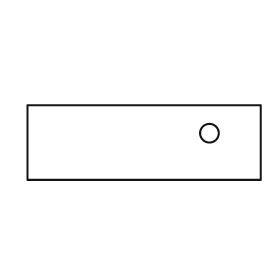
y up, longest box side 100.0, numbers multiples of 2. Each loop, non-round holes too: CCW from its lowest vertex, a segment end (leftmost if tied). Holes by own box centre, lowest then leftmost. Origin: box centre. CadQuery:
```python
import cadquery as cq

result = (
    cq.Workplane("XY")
    .moveTo(-50.0, -16.0)
    .lineTo(50.0, -16.0)
    .lineTo(50.0, 16.0)
    .lineTo(-50.0, 16.0)
    .close()
    .moveTo(28.0, 4.0)
    .circle(4.0)
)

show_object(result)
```